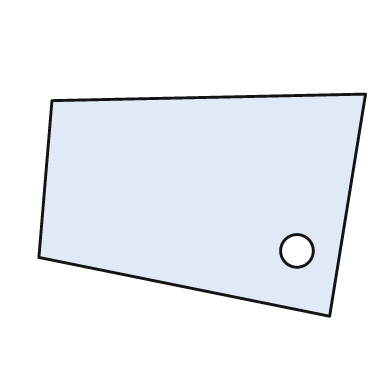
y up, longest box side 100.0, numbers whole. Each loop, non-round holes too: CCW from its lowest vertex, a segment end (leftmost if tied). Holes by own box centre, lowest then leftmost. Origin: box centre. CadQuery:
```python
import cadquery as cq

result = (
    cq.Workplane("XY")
    .moveTo(39.0, -34.0)
    .lineTo(50.0, 34.0)
    .lineTo(-46.0, 32.0)
    .lineTo(-50.0, -16.0)
    .close()
    .moveTo(29.0, -14.0)
    .circle(5.0)
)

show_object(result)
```